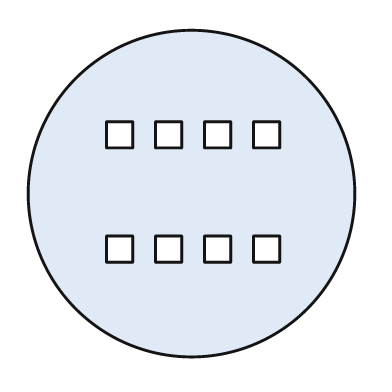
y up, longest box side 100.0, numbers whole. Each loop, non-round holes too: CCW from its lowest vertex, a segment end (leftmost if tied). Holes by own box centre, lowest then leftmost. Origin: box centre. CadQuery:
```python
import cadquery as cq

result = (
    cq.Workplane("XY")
    .moveTo(0.0, 0.0)
    .circle(50.0)
    .moveTo(-26.0, -21.0)
    .lineTo(-18.0, -21.0)
    .lineTo(-18.0, -13.0)
    .lineTo(-26.0, -13.0)
    .close()
    .moveTo(-11.0, -21.0)
    .lineTo(-3.0, -21.0)
    .lineTo(-3.0, -13.0)
    .lineTo(-11.0, -13.0)
    .close()
    .moveTo(4.0, -21.0)
    .lineTo(12.0, -21.0)
    .lineTo(12.0, -13.0)
    .lineTo(4.0, -13.0)
    .close()
    .moveTo(19.0, -21.0)
    .lineTo(27.0, -21.0)
    .lineTo(27.0, -13.0)
    .lineTo(19.0, -13.0)
    .close()
    .moveTo(-26.0, 14.0)
    .lineTo(-18.0, 14.0)
    .lineTo(-18.0, 22.0)
    .lineTo(-26.0, 22.0)
    .close()
    .moveTo(-11.0, 14.0)
    .lineTo(-3.0, 14.0)
    .lineTo(-3.0, 22.0)
    .lineTo(-11.0, 22.0)
    .close()
    .moveTo(4.0, 14.0)
    .lineTo(12.0, 14.0)
    .lineTo(12.0, 22.0)
    .lineTo(4.0, 22.0)
    .close()
    .moveTo(19.0, 14.0)
    .lineTo(27.0, 14.0)
    .lineTo(27.0, 22.0)
    .lineTo(19.0, 22.0)
    .close()
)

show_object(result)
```